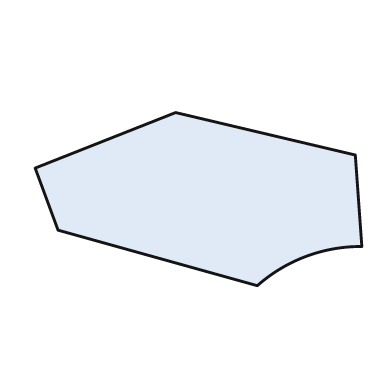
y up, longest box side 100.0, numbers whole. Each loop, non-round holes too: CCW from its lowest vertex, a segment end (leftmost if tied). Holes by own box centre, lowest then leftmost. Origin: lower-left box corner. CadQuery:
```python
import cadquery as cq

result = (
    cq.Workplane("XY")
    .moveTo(68.0, 0.0)
    .threePointArc((83.0, 9.0), (100.0, 12.0))
    .lineTo(98.0, 40.0)
    .lineTo(43.0, 53.0)
    .lineTo(0.0, 36.0)
    .lineTo(7.0, 17.0)
    .close()
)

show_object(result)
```